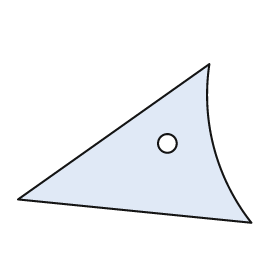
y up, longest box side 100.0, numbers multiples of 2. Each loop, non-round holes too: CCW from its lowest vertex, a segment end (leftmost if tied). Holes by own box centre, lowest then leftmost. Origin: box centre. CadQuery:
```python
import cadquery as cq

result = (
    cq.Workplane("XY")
    .moveTo(50.0, -34.0)
    .threePointArc((34.0, -2.0), (32.0, 34.0))
    .lineTo(-50.0, -24.0)
    .close()
    .moveTo(14.0, 0.0)
    .circle(4.0)
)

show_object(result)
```